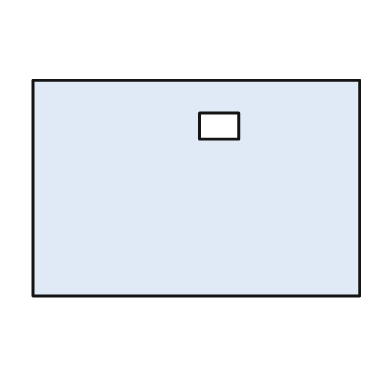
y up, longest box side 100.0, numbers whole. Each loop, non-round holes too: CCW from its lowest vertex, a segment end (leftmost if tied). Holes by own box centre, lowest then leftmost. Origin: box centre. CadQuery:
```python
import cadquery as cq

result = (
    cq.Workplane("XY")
    .moveTo(-50.0, -33.0)
    .lineTo(50.0, -33.0)
    .lineTo(50.0, 33.0)
    .lineTo(-50.0, 33.0)
    .close()
    .moveTo(1.0, 15.0)
    .lineTo(13.0, 15.0)
    .lineTo(13.0, 23.0)
    .lineTo(1.0, 23.0)
    .close()
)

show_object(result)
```